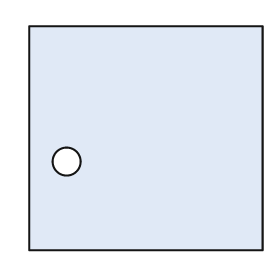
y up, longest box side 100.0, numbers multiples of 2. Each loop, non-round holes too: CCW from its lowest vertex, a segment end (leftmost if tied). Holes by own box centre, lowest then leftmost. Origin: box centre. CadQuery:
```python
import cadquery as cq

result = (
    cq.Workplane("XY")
    .moveTo(-50.0, -48.0)
    .lineTo(50.0, -48.0)
    .lineTo(50.0, 48.0)
    .lineTo(-50.0, 48.0)
    .close()
    .moveTo(-34.0, -10.0)
    .circle(6.0)
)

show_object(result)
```